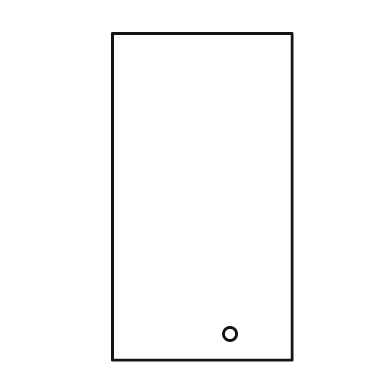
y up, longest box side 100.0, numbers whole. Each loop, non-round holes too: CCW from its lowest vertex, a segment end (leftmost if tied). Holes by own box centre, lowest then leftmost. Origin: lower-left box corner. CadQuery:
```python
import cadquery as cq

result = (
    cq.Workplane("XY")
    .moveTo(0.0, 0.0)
    .lineTo(55.0, 0.0)
    .lineTo(55.0, 100.0)
    .lineTo(0.0, 100.0)
    .close()
    .moveTo(36.0, 8.0)
    .circle(2.0)
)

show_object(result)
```